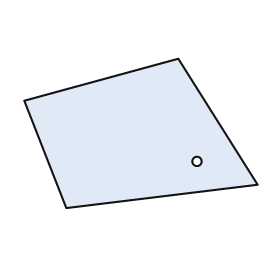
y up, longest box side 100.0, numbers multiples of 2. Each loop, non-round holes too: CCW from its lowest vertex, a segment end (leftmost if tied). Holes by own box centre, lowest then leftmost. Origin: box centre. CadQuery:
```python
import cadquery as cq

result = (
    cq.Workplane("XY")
    .moveTo(-32.0, -32.0)
    .lineTo(50.0, -22.0)
    .lineTo(16.0, 32.0)
    .lineTo(-50.0, 14.0)
    .close()
    .moveTo(24.0, -12.0)
    .circle(2.0)
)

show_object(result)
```